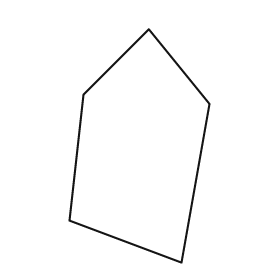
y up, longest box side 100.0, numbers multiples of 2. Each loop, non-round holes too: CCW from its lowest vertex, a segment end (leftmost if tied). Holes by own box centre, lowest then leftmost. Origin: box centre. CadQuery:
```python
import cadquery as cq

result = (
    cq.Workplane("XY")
    .moveTo(18.0, -50.0)
    .lineTo(30.0, 18.0)
    .lineTo(4.0, 50.0)
    .lineTo(-24.0, 22.0)
    .lineTo(-30.0, -32.0)
    .close()
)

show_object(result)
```